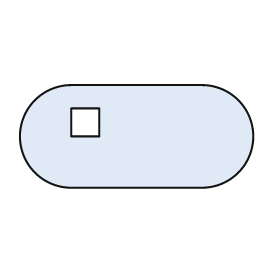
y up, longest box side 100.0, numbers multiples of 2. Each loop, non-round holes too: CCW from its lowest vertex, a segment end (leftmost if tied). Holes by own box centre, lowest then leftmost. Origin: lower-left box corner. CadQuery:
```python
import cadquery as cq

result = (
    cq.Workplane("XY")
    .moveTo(22.0, 0.0)
    .lineTo(78.0, 0.0)
    .threePointArc((100.0, 22.0), (78.0, 44.0))
    .lineTo(22.0, 44.0)
    .threePointArc((0.0, 22.0), (22.0, 0.0))
    .close()
    .moveTo(22.0, 22.0)
    .lineTo(34.0, 22.0)
    .lineTo(34.0, 34.0)
    .lineTo(22.0, 34.0)
    .close()
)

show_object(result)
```